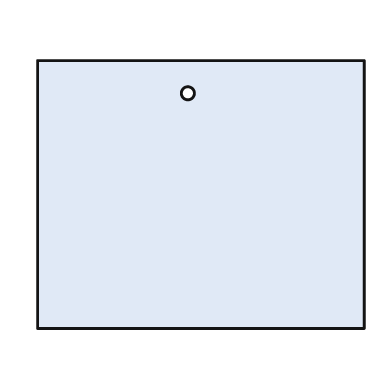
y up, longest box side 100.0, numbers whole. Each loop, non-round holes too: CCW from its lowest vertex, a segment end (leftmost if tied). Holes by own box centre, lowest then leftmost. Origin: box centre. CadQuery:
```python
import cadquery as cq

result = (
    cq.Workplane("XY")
    .moveTo(-50.0, -41.0)
    .lineTo(50.0, -41.0)
    .lineTo(50.0, 41.0)
    .lineTo(-50.0, 41.0)
    .close()
    .moveTo(-4.0, 31.0)
    .circle(2.0)
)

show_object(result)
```